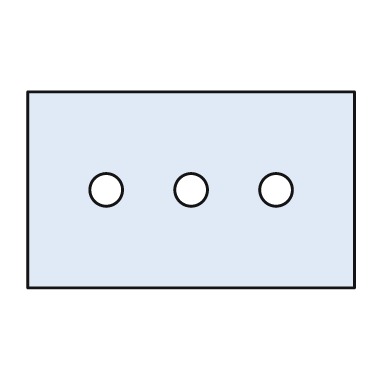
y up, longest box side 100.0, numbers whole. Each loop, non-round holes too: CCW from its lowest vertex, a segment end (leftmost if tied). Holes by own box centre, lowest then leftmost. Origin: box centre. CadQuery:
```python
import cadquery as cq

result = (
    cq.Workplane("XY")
    .moveTo(-50.0, -30.0)
    .lineTo(50.0, -30.0)
    .lineTo(50.0, 30.0)
    .lineTo(-50.0, 30.0)
    .close()
    .moveTo(-26.0, 0.0)
    .circle(5.0)
    .moveTo(0.0, 0.0)
    .circle(5.0)
    .moveTo(26.0, 0.0)
    .circle(5.0)
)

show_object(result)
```